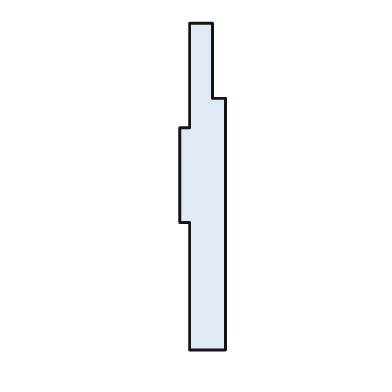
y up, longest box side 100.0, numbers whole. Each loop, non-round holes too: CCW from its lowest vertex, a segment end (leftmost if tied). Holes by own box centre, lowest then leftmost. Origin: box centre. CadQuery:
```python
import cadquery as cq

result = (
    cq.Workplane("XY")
    .moveTo(-4.0, -50.0)
    .lineTo(7.0, -50.0)
    .lineTo(7.0, 27.0)
    .lineTo(3.0, 27.0)
    .lineTo(3.0, 50.0)
    .lineTo(-4.0, 50.0)
    .lineTo(-4.0, 18.0)
    .lineTo(-7.0, 18.0)
    .lineTo(-7.0, -11.0)
    .lineTo(-4.0, -11.0)
    .close()
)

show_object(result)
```